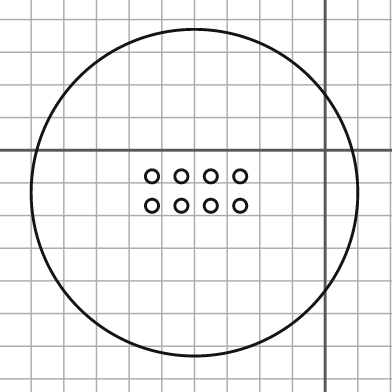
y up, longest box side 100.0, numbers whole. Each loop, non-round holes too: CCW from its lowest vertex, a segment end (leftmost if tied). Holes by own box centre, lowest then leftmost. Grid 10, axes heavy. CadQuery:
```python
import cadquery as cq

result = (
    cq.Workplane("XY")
    .moveTo(-40.0, -13.0)
    .circle(50.0)
    .moveTo(-53.0, -17.0)
    .circle(2.0)
    .moveTo(-44.0, -17.0)
    .circle(2.0)
    .moveTo(-35.0, -17.0)
    .circle(2.0)
    .moveTo(-26.0, -17.0)
    .circle(2.0)
    .moveTo(-53.0, -8.0)
    .circle(2.0)
    .moveTo(-44.0, -8.0)
    .circle(2.0)
    .moveTo(-35.0, -8.0)
    .circle(2.0)
    .moveTo(-26.0, -8.0)
    .circle(2.0)
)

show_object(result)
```